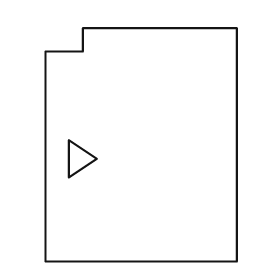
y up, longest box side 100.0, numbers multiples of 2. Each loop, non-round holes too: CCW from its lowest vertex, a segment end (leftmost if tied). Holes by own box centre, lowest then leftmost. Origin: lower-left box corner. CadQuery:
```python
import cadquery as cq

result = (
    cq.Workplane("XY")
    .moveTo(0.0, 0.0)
    .lineTo(82.0, 0.0)
    .lineTo(82.0, 100.0)
    .lineTo(16.0, 100.0)
    .lineTo(16.0, 90.0)
    .lineTo(0.0, 90.0)
    .close()
    .moveTo(10.0, 36.0)
    .lineTo(22.0, 44.0)
    .lineTo(10.0, 52.0)
    .close()
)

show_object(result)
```